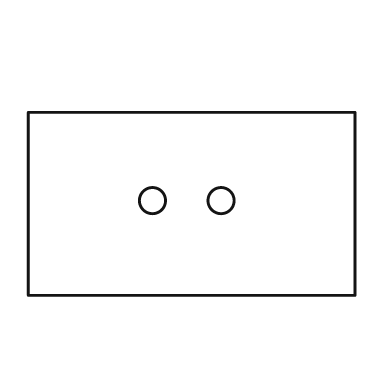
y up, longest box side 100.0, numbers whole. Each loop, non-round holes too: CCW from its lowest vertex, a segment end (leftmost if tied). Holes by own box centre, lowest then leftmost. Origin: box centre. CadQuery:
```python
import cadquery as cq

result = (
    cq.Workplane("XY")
    .moveTo(-50.0, -28.0)
    .lineTo(50.0, -28.0)
    .lineTo(50.0, 28.0)
    .lineTo(-50.0, 28.0)
    .close()
    .moveTo(-12.0, 1.0)
    .circle(4.0)
    .moveTo(9.0, 1.0)
    .circle(4.0)
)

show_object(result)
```